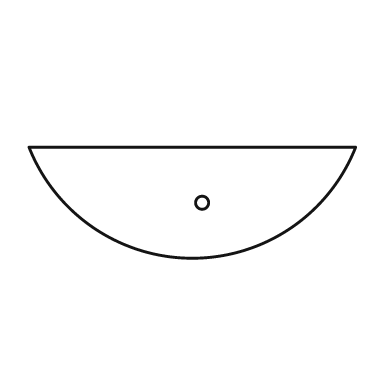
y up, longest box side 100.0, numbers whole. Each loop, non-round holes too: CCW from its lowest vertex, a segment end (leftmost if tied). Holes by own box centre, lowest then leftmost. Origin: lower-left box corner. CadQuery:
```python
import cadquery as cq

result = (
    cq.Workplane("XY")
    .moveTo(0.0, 34.0)
    .threePointArc((50.0, 0.0), (100.0, 34.0))
    .close()
    .moveTo(53.0, 17.0)
    .circle(2.0)
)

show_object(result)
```